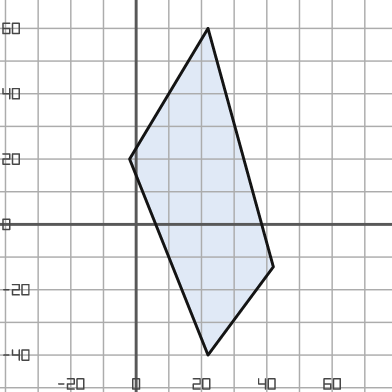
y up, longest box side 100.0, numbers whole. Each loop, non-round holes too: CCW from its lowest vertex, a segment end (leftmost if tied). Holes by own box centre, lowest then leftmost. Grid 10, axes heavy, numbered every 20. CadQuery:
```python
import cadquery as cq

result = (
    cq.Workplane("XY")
    .moveTo(22.0, -40.0)
    .lineTo(42.0, -13.0)
    .lineTo(22.0, 60.0)
    .lineTo(-2.0, 20.0)
    .close()
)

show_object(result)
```